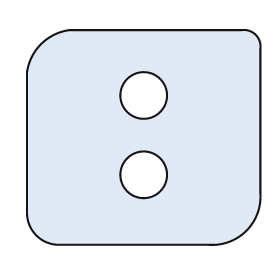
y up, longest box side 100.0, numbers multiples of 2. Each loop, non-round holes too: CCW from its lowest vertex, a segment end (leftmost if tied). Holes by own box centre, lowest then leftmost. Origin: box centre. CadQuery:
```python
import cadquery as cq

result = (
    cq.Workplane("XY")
    .moveTo(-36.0, -46.0)
    .lineTo(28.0, -46.0)
    .threePointArc((44.0, -40.0), (50.0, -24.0))
    .lineTo(50.0, 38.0)
    .threePointArc((48.0, 44.0), (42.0, 46.0))
    .lineTo(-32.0, 46.0)
    .threePointArc((-44.0, 40.0), (-50.0, 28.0))
    .lineTo(-50.0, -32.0)
    .threePointArc((-46.0, -42.0), (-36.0, -46.0))
    .close()
    .moveTo(0.0, -16.0)
    .circle(10.0)
    .moveTo(0.0, 18.0)
    .circle(10.0)
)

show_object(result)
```